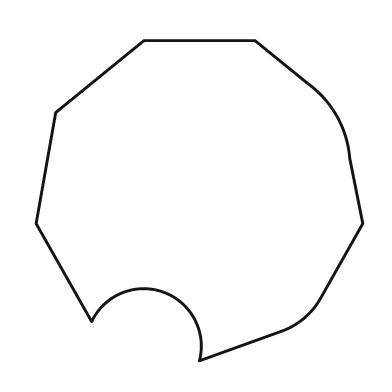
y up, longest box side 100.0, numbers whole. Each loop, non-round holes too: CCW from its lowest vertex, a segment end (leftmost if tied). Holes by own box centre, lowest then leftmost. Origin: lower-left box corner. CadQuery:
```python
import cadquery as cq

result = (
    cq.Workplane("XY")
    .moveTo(50.0, 0.0)
    .lineTo(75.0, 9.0)
    .threePointArc((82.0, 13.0), (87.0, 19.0))
    .lineTo(100.0, 42.0)
    .lineTo(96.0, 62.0)
    .threePointArc((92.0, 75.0), (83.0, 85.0))
    .lineTo(67.0, 98.0)
    .lineTo(33.0, 98.0)
    .lineTo(6.0, 76.0)
    .lineTo(0.0, 42.0)
    .lineTo(17.0, 12.0)
    .threePointArc((39.0, 21.0), (50.0, 0.0))
    .close()
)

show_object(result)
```